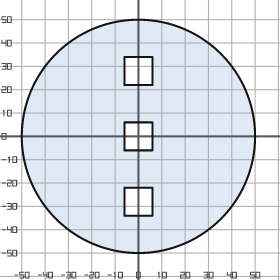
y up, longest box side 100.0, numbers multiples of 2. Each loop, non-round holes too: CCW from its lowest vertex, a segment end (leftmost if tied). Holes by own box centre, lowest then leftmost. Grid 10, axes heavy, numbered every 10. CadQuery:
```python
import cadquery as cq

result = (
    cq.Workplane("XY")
    .moveTo(0.0, 0.0)
    .circle(50.0)
    .moveTo(-6.0, -34.0)
    .lineTo(6.0, -34.0)
    .lineTo(6.0, -22.0)
    .lineTo(-6.0, -22.0)
    .close()
    .moveTo(-6.0, -6.0)
    .lineTo(6.0, -6.0)
    .lineTo(6.0, 6.0)
    .lineTo(-6.0, 6.0)
    .close()
    .moveTo(-6.0, 22.0)
    .lineTo(6.0, 22.0)
    .lineTo(6.0, 34.0)
    .lineTo(-6.0, 34.0)
    .close()
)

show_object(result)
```